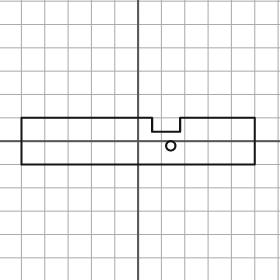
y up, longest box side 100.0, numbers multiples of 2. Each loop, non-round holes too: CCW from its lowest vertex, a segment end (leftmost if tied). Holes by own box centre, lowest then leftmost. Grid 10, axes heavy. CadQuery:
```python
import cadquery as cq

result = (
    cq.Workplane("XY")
    .moveTo(-50.0, -10.0)
    .lineTo(50.0, -10.0)
    .lineTo(50.0, 10.0)
    .lineTo(18.0, 10.0)
    .lineTo(18.0, 4.0)
    .lineTo(6.0, 4.0)
    .lineTo(6.0, 10.0)
    .lineTo(-50.0, 10.0)
    .close()
    .moveTo(14.0, -2.0)
    .circle(2.0)
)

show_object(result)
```